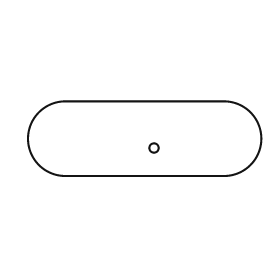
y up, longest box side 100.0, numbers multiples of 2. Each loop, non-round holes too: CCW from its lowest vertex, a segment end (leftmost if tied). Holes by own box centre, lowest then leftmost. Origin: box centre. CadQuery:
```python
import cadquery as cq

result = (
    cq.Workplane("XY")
    .moveTo(-34.0, -16.0)
    .lineTo(34.0, -16.0)
    .threePointArc((50.0, 0.0), (34.0, 16.0))
    .lineTo(-34.0, 16.0)
    .threePointArc((-50.0, 0.0), (-34.0, -16.0))
    .close()
    .moveTo(4.0, -4.0)
    .circle(2.0)
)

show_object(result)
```